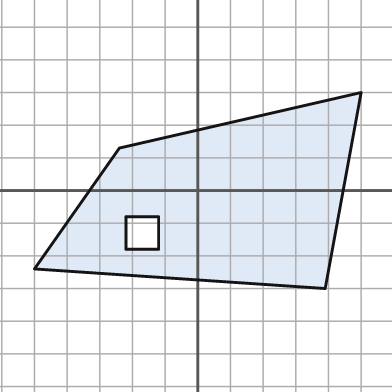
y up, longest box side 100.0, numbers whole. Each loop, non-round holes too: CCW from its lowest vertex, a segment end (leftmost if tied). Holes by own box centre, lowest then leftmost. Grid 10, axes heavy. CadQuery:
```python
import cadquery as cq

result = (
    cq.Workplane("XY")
    .moveTo(39.0, -30.0)
    .lineTo(50.0, 30.0)
    .lineTo(-24.0, 13.0)
    .lineTo(-50.0, -24.0)
    .close()
    .moveTo(-22.0, -18.0)
    .lineTo(-12.0, -18.0)
    .lineTo(-12.0, -8.0)
    .lineTo(-22.0, -8.0)
    .close()
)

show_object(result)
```